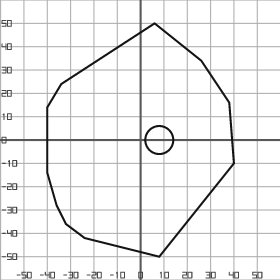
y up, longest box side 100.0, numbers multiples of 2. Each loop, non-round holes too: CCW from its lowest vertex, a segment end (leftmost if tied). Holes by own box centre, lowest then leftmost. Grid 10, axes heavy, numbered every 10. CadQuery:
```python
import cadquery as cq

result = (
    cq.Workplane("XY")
    .moveTo(8.0, -50.0)
    .lineTo(40.0, -10.0)
    .lineTo(38.0, 16.0)
    .lineTo(26.0, 34.0)
    .lineTo(6.0, 50.0)
    .lineTo(-34.0, 24.0)
    .lineTo(-40.0, 14.0)
    .lineTo(-40.0, -14.0)
    .lineTo(-36.0, -28.0)
    .lineTo(-32.0, -36.0)
    .lineTo(-24.0, -42.0)
    .close()
    .moveTo(8.0, 0.0)
    .circle(6.0)
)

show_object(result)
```